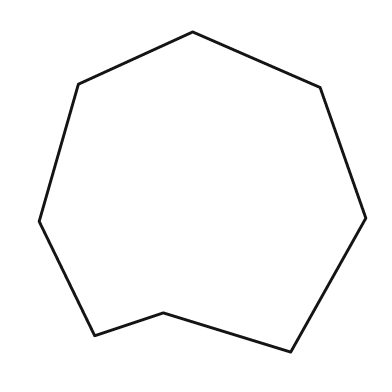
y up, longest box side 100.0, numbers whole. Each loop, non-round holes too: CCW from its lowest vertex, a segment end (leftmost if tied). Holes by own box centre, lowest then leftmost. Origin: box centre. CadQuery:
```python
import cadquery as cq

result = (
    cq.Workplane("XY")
    .moveTo(27.0, -49.0)
    .lineTo(50.0, -8.0)
    .lineTo(36.0, 32.0)
    .lineTo(-3.0, 49.0)
    .lineTo(-38.0, 33.0)
    .lineTo(-50.0, -9.0)
    .lineTo(-33.0, -44.0)
    .lineTo(-12.0, -37.0)
    .close()
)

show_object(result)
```